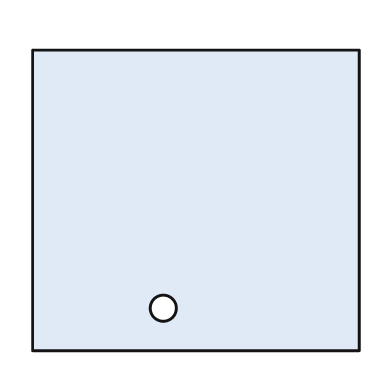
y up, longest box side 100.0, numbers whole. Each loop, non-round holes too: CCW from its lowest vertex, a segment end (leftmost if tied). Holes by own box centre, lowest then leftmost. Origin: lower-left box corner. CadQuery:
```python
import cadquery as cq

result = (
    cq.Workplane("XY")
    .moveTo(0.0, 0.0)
    .lineTo(100.0, 0.0)
    .lineTo(100.0, 92.0)
    .lineTo(0.0, 92.0)
    .close()
    .moveTo(40.0, 13.0)
    .circle(4.0)
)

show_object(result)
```